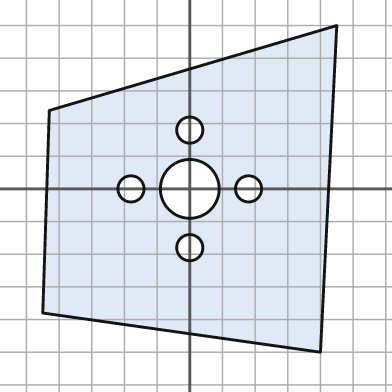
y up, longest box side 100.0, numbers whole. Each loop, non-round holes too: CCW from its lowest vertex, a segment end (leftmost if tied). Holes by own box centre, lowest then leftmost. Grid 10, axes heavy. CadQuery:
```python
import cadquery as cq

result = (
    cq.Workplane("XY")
    .moveTo(40.0, -50.0)
    .lineTo(45.0, 50.0)
    .lineTo(-43.0, 24.0)
    .lineTo(-45.0, -38.0)
    .close()
    .moveTo(0.0, -18.0)
    .circle(4.0)
    .moveTo(-18.0, 0.0)
    .circle(4.0)
    .moveTo(0.0, 0.0)
    .circle(9.0)
    .moveTo(18.0, 0.0)
    .circle(4.0)
    .moveTo(0.0, 18.0)
    .circle(4.0)
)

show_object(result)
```